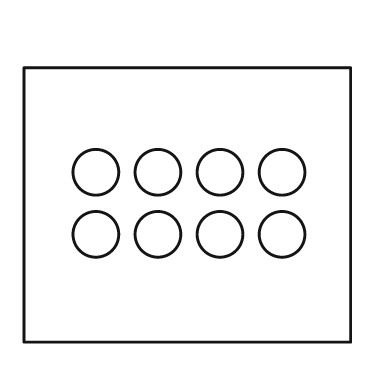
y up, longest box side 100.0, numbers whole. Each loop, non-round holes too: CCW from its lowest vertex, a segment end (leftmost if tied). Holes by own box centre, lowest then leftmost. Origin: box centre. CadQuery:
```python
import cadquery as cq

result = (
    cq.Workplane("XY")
    .moveTo(-50.0, -42.0)
    .lineTo(50.0, -42.0)
    .lineTo(50.0, 42.0)
    .lineTo(-50.0, 42.0)
    .close()
    .moveTo(-28.0, -9.0)
    .circle(7.0)
    .moveTo(-9.0, -9.0)
    .circle(7.0)
    .moveTo(10.0, -9.0)
    .circle(7.0)
    .moveTo(29.0, -9.0)
    .circle(7.0)
    .moveTo(-28.0, 10.0)
    .circle(7.0)
    .moveTo(-9.0, 10.0)
    .circle(7.0)
    .moveTo(10.0, 10.0)
    .circle(7.0)
    .moveTo(29.0, 10.0)
    .circle(7.0)
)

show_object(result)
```